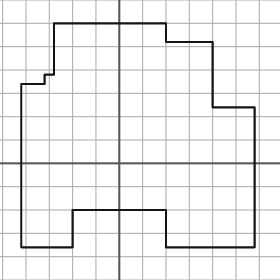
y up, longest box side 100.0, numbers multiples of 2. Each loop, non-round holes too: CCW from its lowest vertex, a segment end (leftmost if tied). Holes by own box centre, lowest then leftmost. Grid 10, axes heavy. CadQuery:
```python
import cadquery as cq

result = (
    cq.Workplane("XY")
    .moveTo(-42.0, -36.0)
    .lineTo(-20.0, -36.0)
    .lineTo(-20.0, -20.0)
    .lineTo(20.0, -20.0)
    .lineTo(20.0, -36.0)
    .lineTo(58.0, -36.0)
    .lineTo(58.0, 24.0)
    .lineTo(40.0, 24.0)
    .lineTo(40.0, 52.0)
    .lineTo(20.0, 52.0)
    .lineTo(20.0, 60.0)
    .lineTo(-28.0, 60.0)
    .lineTo(-28.0, 38.0)
    .lineTo(-32.0, 38.0)
    .lineTo(-32.0, 34.0)
    .lineTo(-42.0, 34.0)
    .close()
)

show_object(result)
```